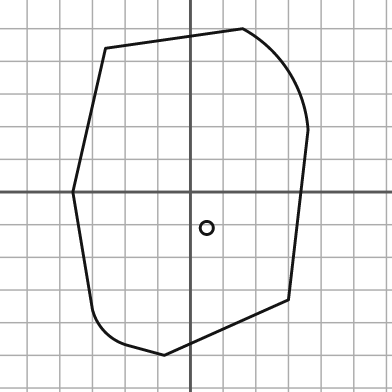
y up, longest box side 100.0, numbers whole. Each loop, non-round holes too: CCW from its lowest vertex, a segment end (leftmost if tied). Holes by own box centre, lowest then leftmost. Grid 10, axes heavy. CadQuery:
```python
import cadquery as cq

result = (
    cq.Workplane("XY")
    .moveTo(-8.0, -50.0)
    .lineTo(30.0, -33.0)
    .lineTo(36.0, 19.0)
    .threePointArc((30.0, 37.0), (16.0, 50.0))
    .lineTo(-26.0, 44.0)
    .lineTo(-36.0, 0.0)
    .lineTo(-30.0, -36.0)
    .threePointArc((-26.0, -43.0), (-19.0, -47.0))
    .close()
    .moveTo(5.0, -11.0)
    .circle(2.0)
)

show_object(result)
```